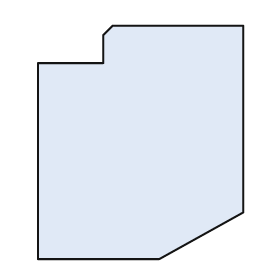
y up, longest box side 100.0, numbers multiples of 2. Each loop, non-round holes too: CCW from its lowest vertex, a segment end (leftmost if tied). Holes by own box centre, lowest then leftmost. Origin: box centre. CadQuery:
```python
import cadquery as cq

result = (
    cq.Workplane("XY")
    .moveTo(-44.0, -50.0)
    .lineTo(8.0, -50.0)
    .lineTo(44.0, -30.0)
    .lineTo(44.0, 50.0)
    .lineTo(-12.0, 50.0)
    .lineTo(-16.0, 46.0)
    .lineTo(-16.0, 34.0)
    .lineTo(-44.0, 34.0)
    .close()
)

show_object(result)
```